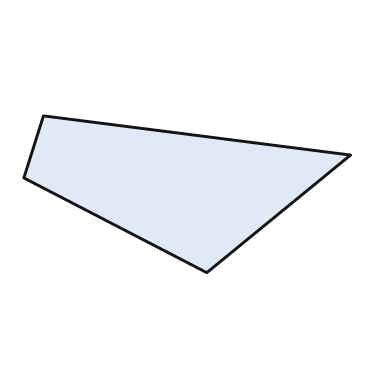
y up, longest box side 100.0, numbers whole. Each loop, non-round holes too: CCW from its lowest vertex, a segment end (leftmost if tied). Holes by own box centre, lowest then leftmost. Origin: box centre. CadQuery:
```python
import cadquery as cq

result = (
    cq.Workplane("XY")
    .moveTo(6.0, -24.0)
    .lineTo(50.0, 12.0)
    .lineTo(-44.0, 24.0)
    .lineTo(-50.0, 5.0)
    .close()
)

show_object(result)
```